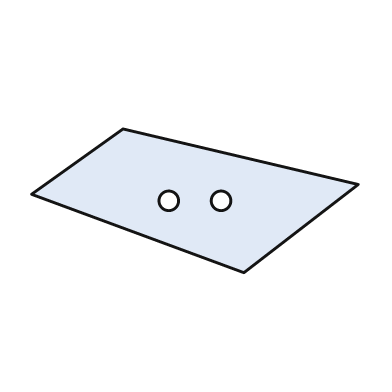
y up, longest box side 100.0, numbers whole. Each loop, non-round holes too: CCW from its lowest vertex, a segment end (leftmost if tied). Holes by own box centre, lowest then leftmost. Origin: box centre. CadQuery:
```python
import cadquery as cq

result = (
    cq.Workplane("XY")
    .moveTo(15.0, -22.0)
    .lineTo(50.0, 5.0)
    .lineTo(-22.0, 22.0)
    .lineTo(-50.0, 2.0)
    .close()
    .moveTo(-8.0, 0.0)
    .circle(3.0)
    .moveTo(8.0, 0.0)
    .circle(3.0)
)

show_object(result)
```